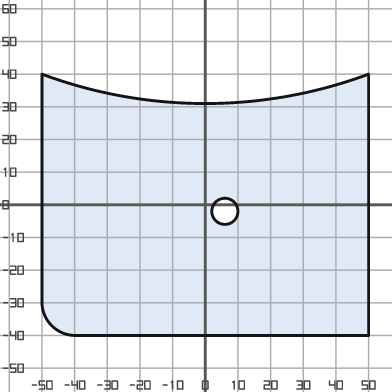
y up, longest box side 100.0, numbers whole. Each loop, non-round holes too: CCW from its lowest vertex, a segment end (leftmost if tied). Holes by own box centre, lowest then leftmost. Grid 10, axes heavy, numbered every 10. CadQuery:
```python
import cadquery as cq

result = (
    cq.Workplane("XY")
    .moveTo(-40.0, -40.0)
    .lineTo(50.0, -40.0)
    .lineTo(50.0, 40.0)
    .threePointArc((0.0, 31.0), (-50.0, 40.0))
    .lineTo(-50.0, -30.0)
    .threePointArc((-47.0, -37.0), (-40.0, -40.0))
    .close()
    .moveTo(6.0, -2.0)
    .circle(4.0)
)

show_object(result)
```